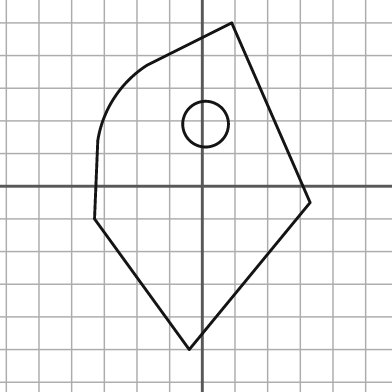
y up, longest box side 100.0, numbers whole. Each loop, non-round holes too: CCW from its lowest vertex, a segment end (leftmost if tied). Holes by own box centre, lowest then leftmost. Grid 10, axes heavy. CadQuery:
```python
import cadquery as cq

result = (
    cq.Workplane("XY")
    .moveTo(-4.0, -50.0)
    .lineTo(33.0, -5.0)
    .lineTo(9.0, 50.0)
    .lineTo(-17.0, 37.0)
    .threePointArc((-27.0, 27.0), (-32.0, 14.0))
    .lineTo(-33.0, -10.0)
    .close()
    .moveTo(1.0, 19.0)
    .circle(7.0)
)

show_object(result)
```